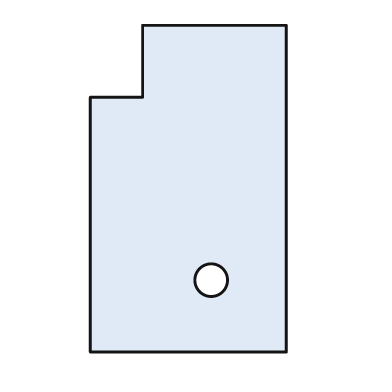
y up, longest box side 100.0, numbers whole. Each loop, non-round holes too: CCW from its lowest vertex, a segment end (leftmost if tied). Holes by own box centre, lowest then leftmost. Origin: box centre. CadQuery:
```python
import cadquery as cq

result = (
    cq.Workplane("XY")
    .moveTo(-30.0, -50.0)
    .lineTo(30.0, -50.0)
    .lineTo(30.0, 50.0)
    .lineTo(-14.0, 50.0)
    .lineTo(-14.0, 28.0)
    .lineTo(-30.0, 28.0)
    .close()
    .moveTo(7.0, -28.0)
    .circle(5.0)
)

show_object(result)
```